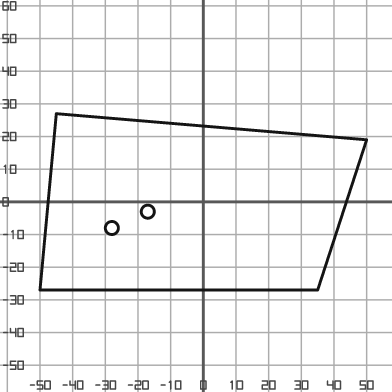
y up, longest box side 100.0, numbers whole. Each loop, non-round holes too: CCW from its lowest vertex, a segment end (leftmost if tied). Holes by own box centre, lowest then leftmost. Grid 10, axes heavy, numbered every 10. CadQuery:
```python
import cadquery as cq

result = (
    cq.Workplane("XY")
    .moveTo(-50.0, -27.0)
    .lineTo(35.0, -27.0)
    .lineTo(50.0, 19.0)
    .lineTo(-45.0, 27.0)
    .close()
    .moveTo(-28.0, -8.0)
    .circle(2.0)
    .moveTo(-17.0, -3.0)
    .circle(2.0)
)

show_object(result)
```